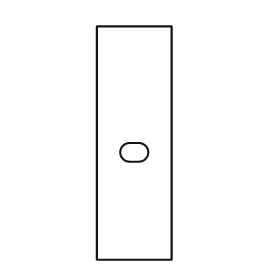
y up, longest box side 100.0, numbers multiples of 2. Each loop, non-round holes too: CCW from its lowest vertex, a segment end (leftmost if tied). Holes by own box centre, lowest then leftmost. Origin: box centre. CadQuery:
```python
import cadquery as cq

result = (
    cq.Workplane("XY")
    .moveTo(-16.0, -50.0)
    .lineTo(16.0, -50.0)
    .lineTo(16.0, 50.0)
    .lineTo(-16.0, 50.0)
    .close()
    .moveTo(-2.0, -8.0)
    .lineTo(2.0, -8.0)
    .threePointArc((6.0, -4.0), (2.0, 0.0))
    .lineTo(-2.0, 0.0)
    .threePointArc((-6.0, -4.0), (-2.0, -8.0))
    .close()
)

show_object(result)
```